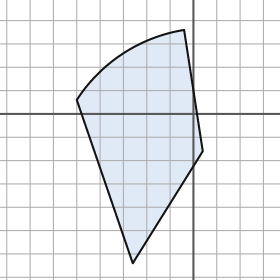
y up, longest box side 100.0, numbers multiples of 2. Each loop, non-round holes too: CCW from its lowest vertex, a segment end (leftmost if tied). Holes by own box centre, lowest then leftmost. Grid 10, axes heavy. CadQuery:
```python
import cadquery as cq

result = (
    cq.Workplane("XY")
    .moveTo(-26.0, -64.0)
    .lineTo(4.0, -16.0)
    .lineTo(-4.0, 36.0)
    .threePointArc((-30.0, 26.0), (-50.0, 6.0))
    .close()
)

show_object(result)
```